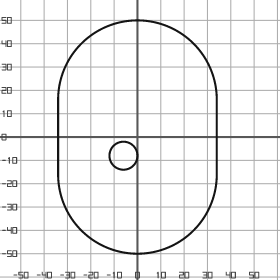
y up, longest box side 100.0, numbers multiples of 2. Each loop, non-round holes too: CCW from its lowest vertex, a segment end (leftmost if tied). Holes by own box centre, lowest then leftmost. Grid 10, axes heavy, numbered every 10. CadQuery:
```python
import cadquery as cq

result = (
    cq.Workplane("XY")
    .moveTo(-34.0, -16.0)
    .threePointArc((0.0, -50.0), (34.0, -16.0))
    .lineTo(34.0, 16.0)
    .threePointArc((0.0, 50.0), (-34.0, 16.0))
    .close()
    .moveTo(-6.0, -8.0)
    .circle(6.0)
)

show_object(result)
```